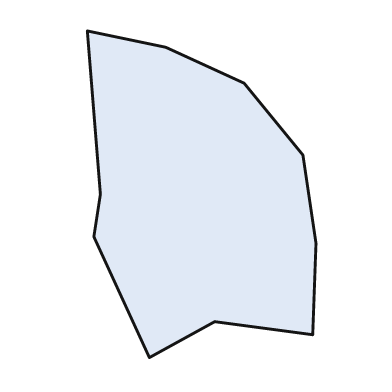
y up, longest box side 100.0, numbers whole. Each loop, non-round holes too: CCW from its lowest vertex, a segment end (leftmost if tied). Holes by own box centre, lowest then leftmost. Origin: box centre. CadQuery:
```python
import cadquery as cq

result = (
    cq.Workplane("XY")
    .moveTo(-16.0, -50.0)
    .lineTo(4.0, -39.0)
    .lineTo(34.0, -43.0)
    .lineTo(35.0, -15.0)
    .lineTo(31.0, 12.0)
    .lineTo(13.0, 34.0)
    .lineTo(-11.0, 45.0)
    .lineTo(-35.0, 50.0)
    .lineTo(-31.0, 0.0)
    .lineTo(-33.0, -13.0)
    .close()
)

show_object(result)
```